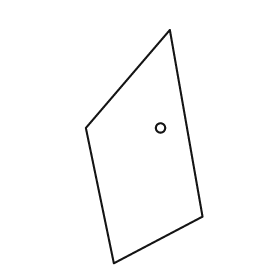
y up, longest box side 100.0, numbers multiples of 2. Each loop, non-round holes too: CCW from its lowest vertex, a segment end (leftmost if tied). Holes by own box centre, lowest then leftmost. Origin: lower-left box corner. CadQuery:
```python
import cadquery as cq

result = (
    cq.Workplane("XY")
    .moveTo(12.0, 0.0)
    .lineTo(50.0, 20.0)
    .lineTo(36.0, 100.0)
    .lineTo(0.0, 58.0)
    .close()
    .moveTo(32.0, 58.0)
    .circle(2.0)
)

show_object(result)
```